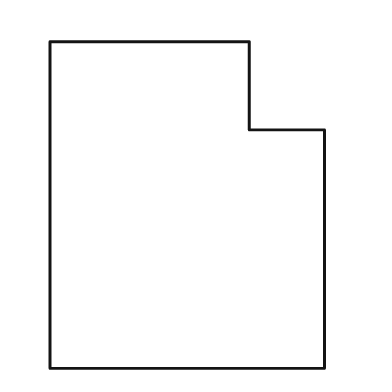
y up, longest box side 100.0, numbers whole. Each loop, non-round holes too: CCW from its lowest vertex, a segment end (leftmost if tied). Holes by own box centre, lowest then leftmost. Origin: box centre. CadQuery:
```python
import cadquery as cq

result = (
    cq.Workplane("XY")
    .moveTo(-42.0, -50.0)
    .lineTo(42.0, -50.0)
    .lineTo(42.0, 23.0)
    .lineTo(19.0, 23.0)
    .lineTo(19.0, 50.0)
    .lineTo(-42.0, 50.0)
    .close()
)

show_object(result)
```